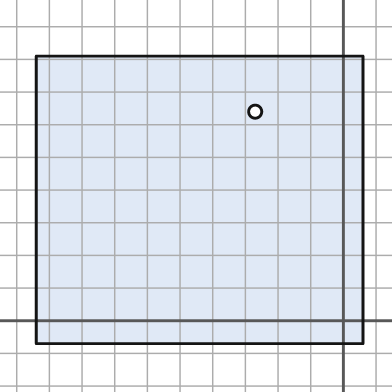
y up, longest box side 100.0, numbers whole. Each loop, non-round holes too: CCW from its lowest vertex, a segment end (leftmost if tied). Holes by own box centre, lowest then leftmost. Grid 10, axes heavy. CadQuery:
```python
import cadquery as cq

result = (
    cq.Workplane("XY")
    .moveTo(-94.0, -7.0)
    .lineTo(6.0, -7.0)
    .lineTo(6.0, 81.0)
    .lineTo(-94.0, 81.0)
    .close()
    .moveTo(-27.0, 64.0)
    .circle(2.0)
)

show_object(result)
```